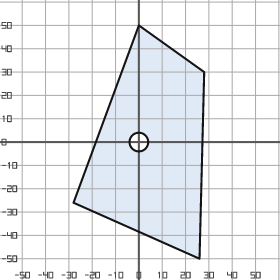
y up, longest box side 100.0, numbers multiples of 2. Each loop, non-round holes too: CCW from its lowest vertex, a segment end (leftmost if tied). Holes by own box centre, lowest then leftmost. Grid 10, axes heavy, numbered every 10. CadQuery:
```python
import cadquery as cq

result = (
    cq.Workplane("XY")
    .moveTo(26.0, -50.0)
    .lineTo(28.0, 30.0)
    .lineTo(0.0, 50.0)
    .lineTo(-28.0, -26.0)
    .close()
    .moveTo(0.0, 0.0)
    .circle(4.0)
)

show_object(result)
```